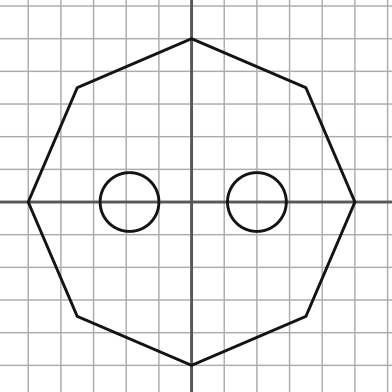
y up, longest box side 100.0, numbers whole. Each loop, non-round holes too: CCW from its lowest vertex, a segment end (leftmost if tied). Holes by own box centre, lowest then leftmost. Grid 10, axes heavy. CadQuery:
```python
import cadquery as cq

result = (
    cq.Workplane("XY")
    .moveTo(0.0, -50.0)
    .lineTo(35.0, -35.0)
    .lineTo(50.0, 0.0)
    .lineTo(35.0, 35.0)
    .lineTo(0.0, 50.0)
    .lineTo(-35.0, 35.0)
    .lineTo(-50.0, 0.0)
    .lineTo(-35.0, -35.0)
    .close()
    .moveTo(-19.0, 0.0)
    .circle(9.0)
    .moveTo(20.0, 0.0)
    .circle(9.0)
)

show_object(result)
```